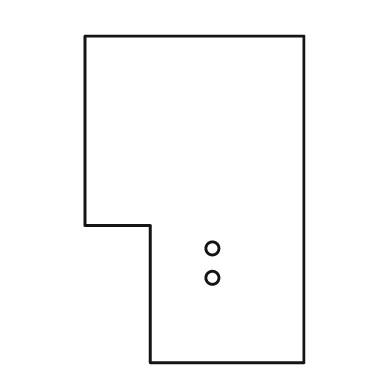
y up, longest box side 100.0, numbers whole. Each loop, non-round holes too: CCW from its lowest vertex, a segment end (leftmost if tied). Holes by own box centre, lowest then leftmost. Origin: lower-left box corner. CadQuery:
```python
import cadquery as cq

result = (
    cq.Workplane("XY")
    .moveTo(20.0, 0.0)
    .lineTo(67.0, 0.0)
    .lineTo(67.0, 100.0)
    .lineTo(0.0, 100.0)
    .lineTo(0.0, 42.0)
    .lineTo(20.0, 42.0)
    .close()
    .moveTo(39.0, 26.0)
    .circle(2.0)
    .moveTo(39.0, 35.0)
    .circle(2.0)
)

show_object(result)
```